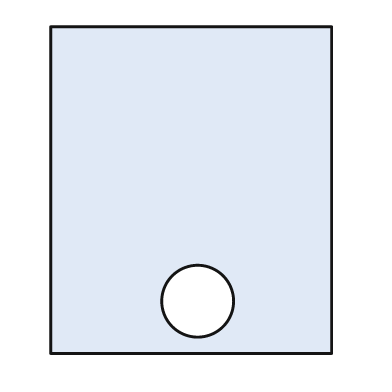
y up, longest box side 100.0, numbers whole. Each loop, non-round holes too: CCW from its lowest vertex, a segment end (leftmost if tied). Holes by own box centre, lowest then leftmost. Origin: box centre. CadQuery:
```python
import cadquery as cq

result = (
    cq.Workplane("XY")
    .moveTo(-43.0, -50.0)
    .lineTo(43.0, -50.0)
    .lineTo(43.0, 50.0)
    .lineTo(-43.0, 50.0)
    .close()
    .moveTo(2.0, -34.0)
    .circle(11.0)
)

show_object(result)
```